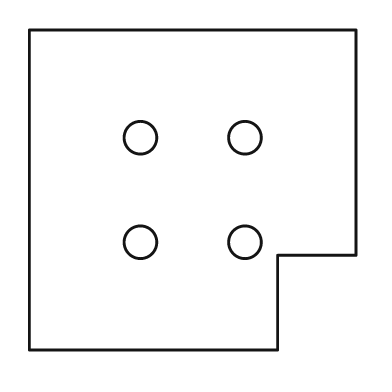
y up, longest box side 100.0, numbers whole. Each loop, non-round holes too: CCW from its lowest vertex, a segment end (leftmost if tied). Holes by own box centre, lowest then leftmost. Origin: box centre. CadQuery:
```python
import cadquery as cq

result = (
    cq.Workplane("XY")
    .moveTo(-50.0, -49.0)
    .lineTo(26.0, -49.0)
    .lineTo(26.0, -20.0)
    .lineTo(50.0, -20.0)
    .lineTo(50.0, 49.0)
    .lineTo(-50.0, 49.0)
    .close()
    .moveTo(-16.0, -16.0)
    .circle(5.0)
    .moveTo(16.0, -16.0)
    .circle(5.0)
    .moveTo(-16.0, 16.0)
    .circle(5.0)
    .moveTo(16.0, 16.0)
    .circle(5.0)
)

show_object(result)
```